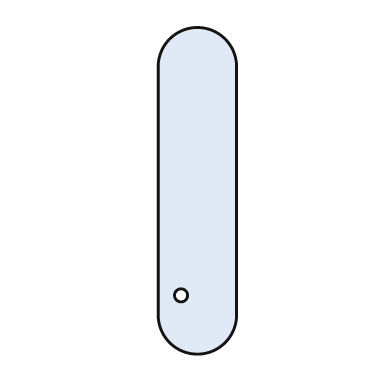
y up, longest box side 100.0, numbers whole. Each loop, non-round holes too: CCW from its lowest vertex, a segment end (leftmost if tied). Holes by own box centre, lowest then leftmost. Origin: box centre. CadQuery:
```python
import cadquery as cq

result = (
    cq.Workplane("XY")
    .moveTo(-12.0, -38.0)
    .threePointArc((0.0, -50.0), (12.0, -38.0))
    .lineTo(12.0, 38.0)
    .threePointArc((0.0, 50.0), (-12.0, 38.0))
    .close()
    .moveTo(-5.0, -32.0)
    .circle(2.0)
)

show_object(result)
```